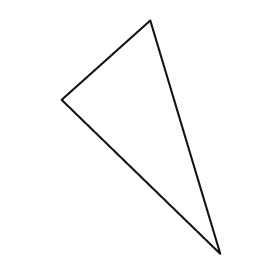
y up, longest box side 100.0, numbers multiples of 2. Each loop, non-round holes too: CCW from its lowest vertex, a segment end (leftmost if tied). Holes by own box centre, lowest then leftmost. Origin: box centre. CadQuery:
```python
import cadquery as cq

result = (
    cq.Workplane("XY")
    .moveTo(34.0, -50.0)
    .lineTo(4.0, 50.0)
    .lineTo(-34.0, 16.0)
    .close()
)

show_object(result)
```